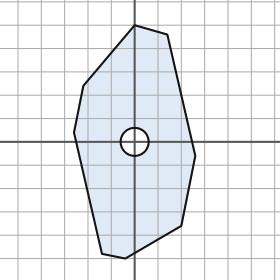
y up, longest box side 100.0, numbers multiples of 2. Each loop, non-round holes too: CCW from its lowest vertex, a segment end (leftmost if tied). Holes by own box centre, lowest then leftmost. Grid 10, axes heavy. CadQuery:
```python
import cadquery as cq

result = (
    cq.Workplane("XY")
    .moveTo(-4.0, -50.0)
    .lineTo(20.0, -36.0)
    .lineTo(26.0, -6.0)
    .lineTo(14.0, 46.0)
    .lineTo(0.0, 50.0)
    .lineTo(-22.0, 24.0)
    .lineTo(-26.0, 4.0)
    .lineTo(-14.0, -48.0)
    .close()
    .moveTo(0.0, 0.0)
    .circle(6.0)
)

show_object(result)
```